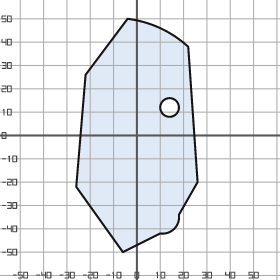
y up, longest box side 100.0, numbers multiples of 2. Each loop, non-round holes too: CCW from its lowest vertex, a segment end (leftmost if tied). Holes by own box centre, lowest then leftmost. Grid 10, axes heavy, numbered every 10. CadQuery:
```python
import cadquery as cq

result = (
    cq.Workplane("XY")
    .moveTo(-6.0, -50.0)
    .lineTo(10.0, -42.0)
    .threePointArc((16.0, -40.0), (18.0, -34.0))
    .lineTo(26.0, -20.0)
    .lineTo(22.0, 38.0)
    .threePointArc((10.0, 46.0), (-4.0, 50.0))
    .lineTo(-22.0, 26.0)
    .lineTo(-26.0, -22.0)
    .close()
    .moveTo(14.0, 12.0)
    .circle(4.0)
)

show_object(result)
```